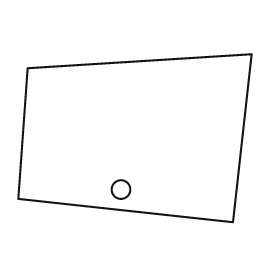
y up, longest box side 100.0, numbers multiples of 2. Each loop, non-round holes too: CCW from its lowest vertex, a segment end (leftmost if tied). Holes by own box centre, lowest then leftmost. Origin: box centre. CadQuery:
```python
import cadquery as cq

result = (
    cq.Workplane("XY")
    .moveTo(42.0, -36.0)
    .lineTo(50.0, 36.0)
    .lineTo(-46.0, 30.0)
    .lineTo(-50.0, -26.0)
    .close()
    .moveTo(-6.0, -22.0)
    .circle(4.0)
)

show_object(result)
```